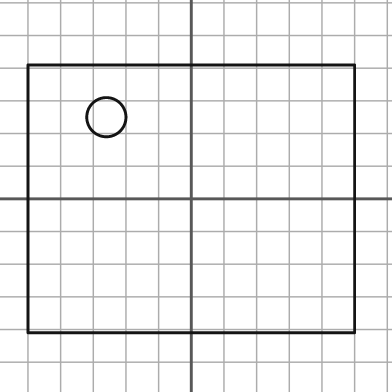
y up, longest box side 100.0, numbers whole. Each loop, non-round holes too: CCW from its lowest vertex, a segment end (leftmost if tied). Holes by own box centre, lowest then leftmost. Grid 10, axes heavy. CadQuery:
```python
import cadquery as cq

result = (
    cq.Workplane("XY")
    .moveTo(-50.0, -41.0)
    .lineTo(50.0, -41.0)
    .lineTo(50.0, 41.0)
    .lineTo(-50.0, 41.0)
    .close()
    .moveTo(-26.0, 25.0)
    .circle(6.0)
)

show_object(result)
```